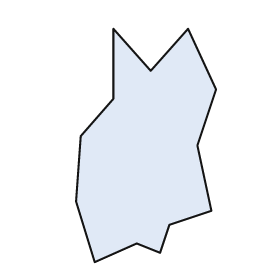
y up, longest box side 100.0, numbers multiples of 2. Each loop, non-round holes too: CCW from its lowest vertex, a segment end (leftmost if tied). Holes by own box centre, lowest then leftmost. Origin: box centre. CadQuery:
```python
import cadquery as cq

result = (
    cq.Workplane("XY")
    .moveTo(-22.0, -50.0)
    .lineTo(-4.0, -42.0)
    .lineTo(6.0, -46.0)
    .lineTo(10.0, -34.0)
    .lineTo(28.0, -28.0)
    .lineTo(22.0, 0.0)
    .lineTo(30.0, 24.0)
    .lineTo(18.0, 50.0)
    .lineTo(2.0, 32.0)
    .lineTo(-14.0, 50.0)
    .lineTo(-14.0, 20.0)
    .lineTo(-28.0, 4.0)
    .lineTo(-30.0, -24.0)
    .close()
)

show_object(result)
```